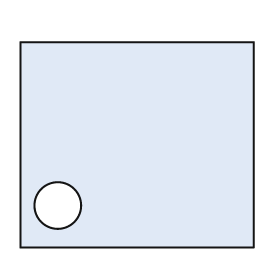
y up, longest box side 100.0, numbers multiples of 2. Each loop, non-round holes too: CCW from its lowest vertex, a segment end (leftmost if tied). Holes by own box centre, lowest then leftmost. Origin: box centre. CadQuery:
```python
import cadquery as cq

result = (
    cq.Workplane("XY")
    .moveTo(-50.0, -44.0)
    .lineTo(50.0, -44.0)
    .lineTo(50.0, 44.0)
    .lineTo(-50.0, 44.0)
    .close()
    .moveTo(-34.0, -26.0)
    .circle(10.0)
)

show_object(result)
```